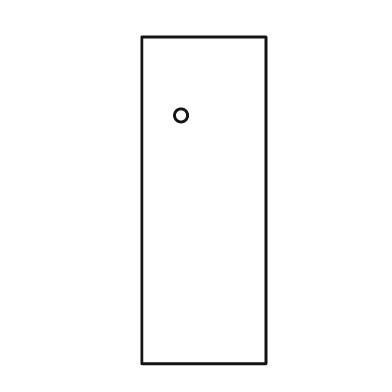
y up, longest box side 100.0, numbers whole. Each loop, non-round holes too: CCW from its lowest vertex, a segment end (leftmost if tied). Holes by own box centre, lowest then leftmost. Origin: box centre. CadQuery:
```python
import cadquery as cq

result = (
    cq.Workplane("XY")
    .moveTo(-19.0, -50.0)
    .lineTo(19.0, -50.0)
    .lineTo(19.0, 50.0)
    .lineTo(-19.0, 50.0)
    .close()
    .moveTo(-7.0, 26.0)
    .circle(2.0)
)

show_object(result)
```